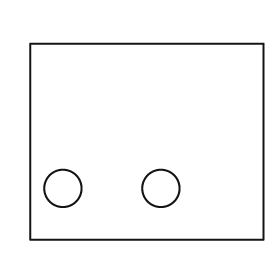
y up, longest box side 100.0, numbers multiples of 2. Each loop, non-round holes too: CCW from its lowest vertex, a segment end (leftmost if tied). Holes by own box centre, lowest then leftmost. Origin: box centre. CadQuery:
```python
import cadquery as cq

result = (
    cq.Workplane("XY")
    .moveTo(-50.0, -42.0)
    .lineTo(50.0, -42.0)
    .lineTo(50.0, 42.0)
    .lineTo(-50.0, 42.0)
    .close()
    .moveTo(-36.0, -20.0)
    .circle(8.0)
    .moveTo(6.0, -20.0)
    .circle(8.0)
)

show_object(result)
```